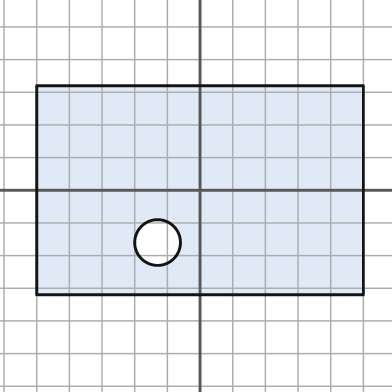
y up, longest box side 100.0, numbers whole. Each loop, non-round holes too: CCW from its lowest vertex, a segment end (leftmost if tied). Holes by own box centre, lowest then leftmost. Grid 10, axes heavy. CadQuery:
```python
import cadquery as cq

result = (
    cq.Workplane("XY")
    .moveTo(-50.0, -32.0)
    .lineTo(50.0, -32.0)
    .lineTo(50.0, 32.0)
    .lineTo(-50.0, 32.0)
    .close()
    .moveTo(-13.0, -16.0)
    .circle(7.0)
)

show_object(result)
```